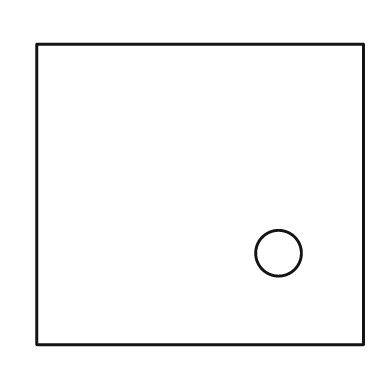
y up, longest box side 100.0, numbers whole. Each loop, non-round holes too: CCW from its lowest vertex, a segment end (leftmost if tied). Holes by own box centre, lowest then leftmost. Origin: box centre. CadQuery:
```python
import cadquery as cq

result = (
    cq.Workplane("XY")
    .moveTo(-50.0, -46.0)
    .lineTo(50.0, -46.0)
    .lineTo(50.0, 46.0)
    .lineTo(-50.0, 46.0)
    .close()
    .moveTo(24.0, -18.0)
    .circle(7.0)
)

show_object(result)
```